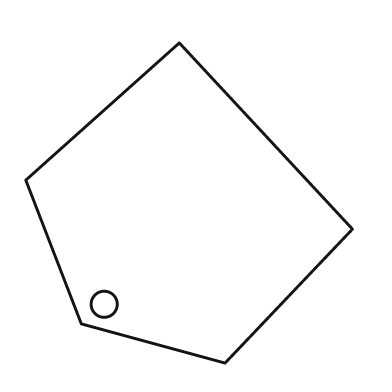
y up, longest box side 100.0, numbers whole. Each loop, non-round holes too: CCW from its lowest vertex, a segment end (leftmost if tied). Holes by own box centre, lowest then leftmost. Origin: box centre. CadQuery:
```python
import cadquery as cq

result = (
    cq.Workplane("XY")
    .moveTo(11.0, -49.0)
    .lineTo(50.0, -8.0)
    .lineTo(-3.0, 49.0)
    .lineTo(-50.0, 7.0)
    .lineTo(-33.0, -37.0)
    .close()
    .moveTo(-26.0, -31.0)
    .circle(4.0)
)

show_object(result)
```